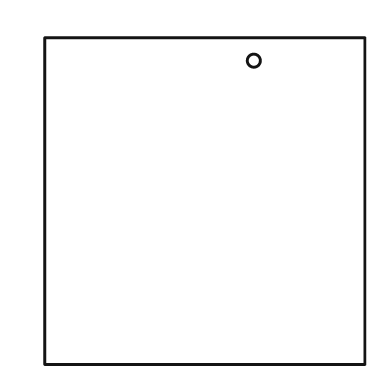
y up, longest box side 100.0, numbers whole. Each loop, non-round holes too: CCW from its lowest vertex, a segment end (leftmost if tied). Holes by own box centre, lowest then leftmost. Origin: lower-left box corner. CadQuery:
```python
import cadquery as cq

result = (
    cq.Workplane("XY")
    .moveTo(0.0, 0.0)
    .lineTo(98.0, 0.0)
    .lineTo(98.0, 100.0)
    .lineTo(0.0, 100.0)
    .close()
    .moveTo(64.0, 93.0)
    .circle(2.0)
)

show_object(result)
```